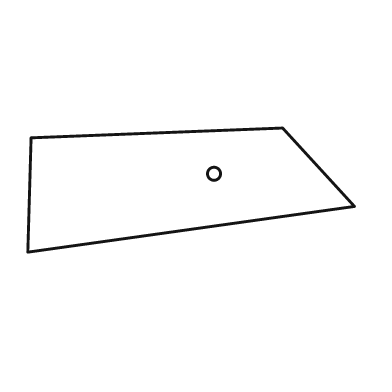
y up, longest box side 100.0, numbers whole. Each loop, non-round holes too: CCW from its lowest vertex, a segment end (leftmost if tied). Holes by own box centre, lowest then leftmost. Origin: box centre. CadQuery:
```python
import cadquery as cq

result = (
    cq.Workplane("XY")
    .moveTo(-50.0, -19.0)
    .lineTo(50.0, -5.0)
    .lineTo(28.0, 19.0)
    .lineTo(-49.0, 16.0)
    .close()
    .moveTo(7.0, 5.0)
    .circle(2.0)
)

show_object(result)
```